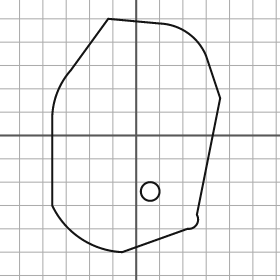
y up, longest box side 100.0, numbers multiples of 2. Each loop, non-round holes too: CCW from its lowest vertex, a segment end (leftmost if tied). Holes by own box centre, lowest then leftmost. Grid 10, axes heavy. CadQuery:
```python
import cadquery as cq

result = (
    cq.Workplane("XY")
    .moveTo(-6.0, -50.0)
    .lineTo(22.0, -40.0)
    .threePointArc((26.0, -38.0), (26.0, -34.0))
    .lineTo(36.0, 16.0)
    .lineTo(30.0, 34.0)
    .threePointArc((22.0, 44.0), (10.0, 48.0))
    .lineTo(-12.0, 50.0)
    .lineTo(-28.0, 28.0)
    .threePointArc((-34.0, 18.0), (-36.0, 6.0))
    .lineTo(-36.0, -30.0)
    .threePointArc((-24.0, -44.0), (-6.0, -50.0))
    .close()
    .moveTo(6.0, -24.0)
    .circle(4.0)
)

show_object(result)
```